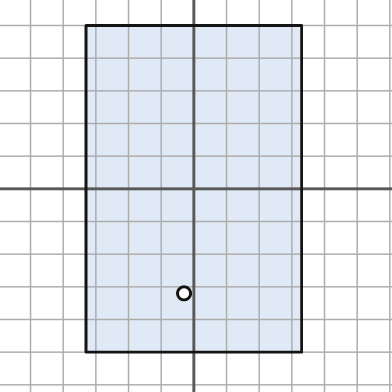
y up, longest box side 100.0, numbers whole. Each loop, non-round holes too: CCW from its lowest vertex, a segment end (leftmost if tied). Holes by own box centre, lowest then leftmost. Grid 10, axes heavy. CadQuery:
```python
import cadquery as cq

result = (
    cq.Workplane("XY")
    .moveTo(-33.0, -50.0)
    .lineTo(33.0, -50.0)
    .lineTo(33.0, 50.0)
    .lineTo(-33.0, 50.0)
    .close()
    .moveTo(-3.0, -32.0)
    .circle(2.0)
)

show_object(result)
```